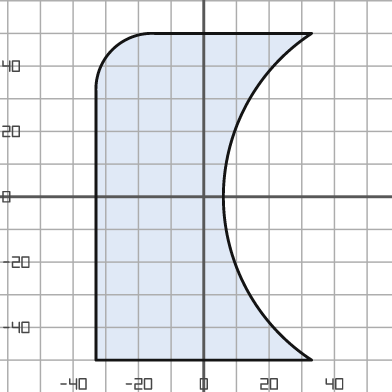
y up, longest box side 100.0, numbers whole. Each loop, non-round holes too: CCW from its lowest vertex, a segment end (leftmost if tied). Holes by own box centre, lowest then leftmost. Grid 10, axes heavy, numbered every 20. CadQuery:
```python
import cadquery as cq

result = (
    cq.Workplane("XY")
    .moveTo(-33.0, -50.0)
    .lineTo(33.0, -50.0)
    .threePointArc((6.0, 0.0), (33.0, 50.0))
    .lineTo(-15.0, 50.0)
    .threePointArc((-28.0, 45.0), (-33.0, 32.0))
    .close()
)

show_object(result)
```